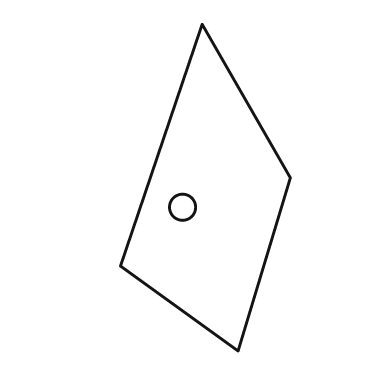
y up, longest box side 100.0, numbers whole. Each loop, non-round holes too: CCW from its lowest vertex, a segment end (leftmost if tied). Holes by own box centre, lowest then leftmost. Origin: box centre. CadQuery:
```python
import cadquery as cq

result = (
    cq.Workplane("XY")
    .moveTo(10.0, -50.0)
    .lineTo(26.0, 3.0)
    .lineTo(-1.0, 50.0)
    .lineTo(-26.0, -24.0)
    .close()
    .moveTo(-7.0, -6.0)
    .circle(4.0)
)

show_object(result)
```